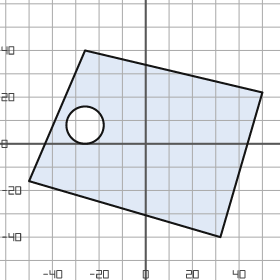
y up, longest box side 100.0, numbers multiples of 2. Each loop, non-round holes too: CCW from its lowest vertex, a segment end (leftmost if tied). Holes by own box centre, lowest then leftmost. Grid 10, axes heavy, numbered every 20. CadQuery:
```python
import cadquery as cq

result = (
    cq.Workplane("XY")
    .moveTo(32.0, -40.0)
    .lineTo(50.0, 22.0)
    .lineTo(-26.0, 40.0)
    .lineTo(-50.0, -16.0)
    .close()
    .moveTo(-26.0, 8.0)
    .circle(8.0)
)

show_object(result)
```